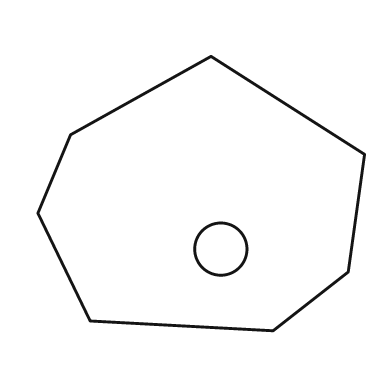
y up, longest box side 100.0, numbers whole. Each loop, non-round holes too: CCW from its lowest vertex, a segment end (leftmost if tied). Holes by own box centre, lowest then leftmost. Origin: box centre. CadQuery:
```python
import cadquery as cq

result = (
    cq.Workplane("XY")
    .moveTo(22.0, -42.0)
    .lineTo(45.0, -24.0)
    .lineTo(50.0, 12.0)
    .lineTo(3.0, 42.0)
    .lineTo(-40.0, 18.0)
    .lineTo(-50.0, -6.0)
    .lineTo(-34.0, -39.0)
    .close()
    .moveTo(6.0, -17.0)
    .circle(8.0)
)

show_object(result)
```